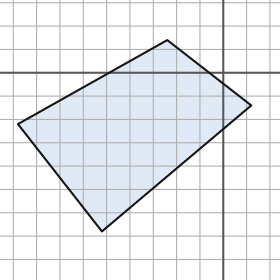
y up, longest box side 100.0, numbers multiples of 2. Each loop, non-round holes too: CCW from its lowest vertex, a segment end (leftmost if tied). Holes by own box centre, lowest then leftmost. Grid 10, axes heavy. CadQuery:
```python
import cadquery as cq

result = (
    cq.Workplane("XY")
    .moveTo(-52.0, -68.0)
    .lineTo(12.0, -14.0)
    .lineTo(-24.0, 14.0)
    .lineTo(-88.0, -22.0)
    .close()
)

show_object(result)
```